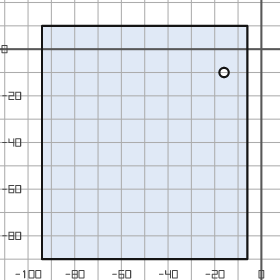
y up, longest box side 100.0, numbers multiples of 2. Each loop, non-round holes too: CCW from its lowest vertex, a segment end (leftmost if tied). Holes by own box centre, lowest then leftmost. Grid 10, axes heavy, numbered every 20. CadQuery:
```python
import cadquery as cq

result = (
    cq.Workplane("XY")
    .moveTo(-94.0, -90.0)
    .lineTo(-6.0, -90.0)
    .lineTo(-6.0, 10.0)
    .lineTo(-94.0, 10.0)
    .close()
    .moveTo(-16.0, -10.0)
    .circle(2.0)
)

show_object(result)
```